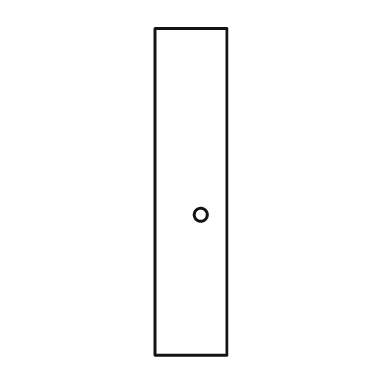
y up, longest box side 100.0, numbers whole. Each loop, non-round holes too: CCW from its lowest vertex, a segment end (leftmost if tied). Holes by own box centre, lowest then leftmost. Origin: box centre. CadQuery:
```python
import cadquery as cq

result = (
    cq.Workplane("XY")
    .moveTo(-11.0, -50.0)
    .lineTo(11.0, -50.0)
    .lineTo(11.0, 50.0)
    .lineTo(-11.0, 50.0)
    .close()
    .moveTo(3.0, -7.0)
    .circle(2.0)
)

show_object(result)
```